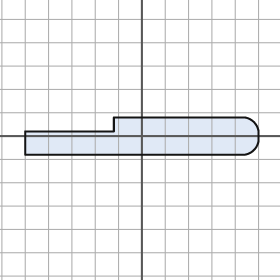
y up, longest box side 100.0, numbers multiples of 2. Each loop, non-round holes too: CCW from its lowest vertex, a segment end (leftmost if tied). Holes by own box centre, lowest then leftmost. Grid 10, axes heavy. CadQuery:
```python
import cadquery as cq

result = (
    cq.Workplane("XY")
    .moveTo(-50.0, -8.0)
    .lineTo(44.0, -8.0)
    .threePointArc((48.0, -6.0), (50.0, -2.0))
    .lineTo(50.0, 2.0)
    .threePointArc((48.0, 6.0), (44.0, 8.0))
    .lineTo(-12.0, 8.0)
    .lineTo(-12.0, 2.0)
    .lineTo(-50.0, 2.0)
    .close()
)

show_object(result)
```